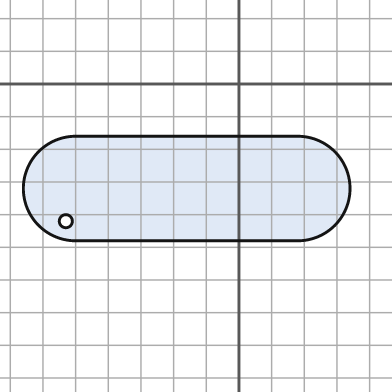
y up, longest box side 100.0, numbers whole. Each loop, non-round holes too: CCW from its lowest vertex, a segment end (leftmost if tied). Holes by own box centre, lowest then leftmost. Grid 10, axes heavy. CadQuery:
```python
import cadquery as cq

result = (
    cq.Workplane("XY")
    .moveTo(-50.0, -48.0)
    .lineTo(18.0, -48.0)
    .threePointArc((34.0, -32.0), (18.0, -16.0))
    .lineTo(-50.0, -16.0)
    .threePointArc((-66.0, -32.0), (-50.0, -48.0))
    .close()
    .moveTo(-53.0, -42.0)
    .circle(2.0)
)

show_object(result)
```